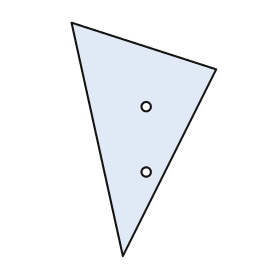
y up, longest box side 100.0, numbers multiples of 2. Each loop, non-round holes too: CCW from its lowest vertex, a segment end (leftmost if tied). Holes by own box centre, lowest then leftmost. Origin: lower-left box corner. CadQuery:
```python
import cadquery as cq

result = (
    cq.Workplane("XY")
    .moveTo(22.0, 0.0)
    .lineTo(62.0, 80.0)
    .lineTo(0.0, 100.0)
    .close()
    .moveTo(32.0, 36.0)
    .circle(2.0)
    .moveTo(32.0, 64.0)
    .circle(2.0)
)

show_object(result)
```